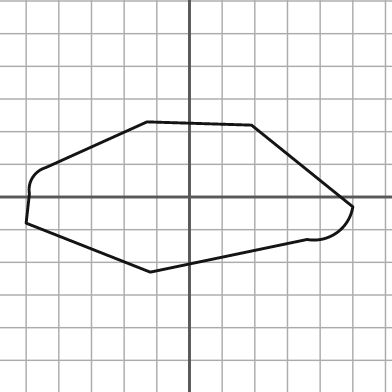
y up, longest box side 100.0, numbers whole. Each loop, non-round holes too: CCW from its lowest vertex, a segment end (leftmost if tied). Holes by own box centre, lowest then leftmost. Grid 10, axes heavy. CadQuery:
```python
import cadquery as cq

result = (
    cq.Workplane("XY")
    .moveTo(-12.0, -23.0)
    .lineTo(36.0, -13.0)
    .threePointArc((45.0, -11.0), (50.0, -3.0))
    .lineTo(19.0, 22.0)
    .lineTo(-13.0, 23.0)
    .lineTo(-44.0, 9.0)
    .threePointArc((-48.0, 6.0), (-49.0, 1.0))
    .lineTo(-50.0, -8.0)
    .close()
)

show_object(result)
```